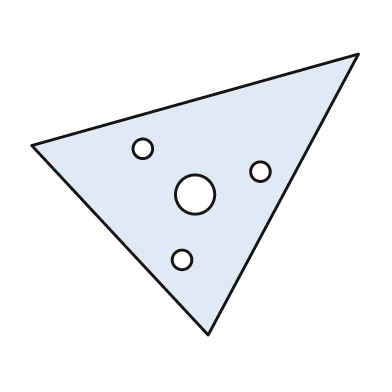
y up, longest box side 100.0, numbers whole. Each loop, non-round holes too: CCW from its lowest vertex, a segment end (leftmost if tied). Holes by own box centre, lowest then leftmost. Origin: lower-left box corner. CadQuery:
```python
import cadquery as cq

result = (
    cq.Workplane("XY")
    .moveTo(54.0, 0.0)
    .lineTo(100.0, 86.0)
    .lineTo(0.0, 58.0)
    .close()
    .moveTo(46.0, 23.0)
    .circle(3.0)
    .moveTo(50.0, 43.0)
    .circle(6.0)
    .moveTo(70.0, 50.0)
    .circle(3.0)
    .moveTo(34.0, 57.0)
    .circle(3.0)
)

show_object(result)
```